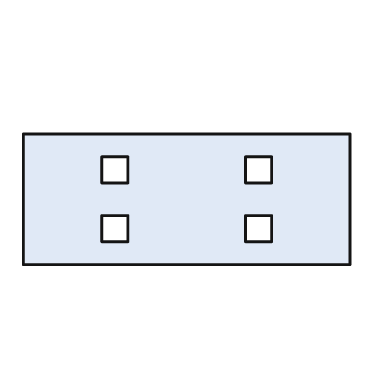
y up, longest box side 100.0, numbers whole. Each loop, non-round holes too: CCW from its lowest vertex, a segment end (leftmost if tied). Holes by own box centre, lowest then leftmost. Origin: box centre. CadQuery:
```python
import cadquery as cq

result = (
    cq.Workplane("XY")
    .moveTo(-50.0, -20.0)
    .lineTo(50.0, -20.0)
    .lineTo(50.0, 20.0)
    .lineTo(-50.0, 20.0)
    .close()
    .moveTo(-26.0, -13.0)
    .lineTo(-18.0, -13.0)
    .lineTo(-18.0, -5.0)
    .lineTo(-26.0, -5.0)
    .close()
    .moveTo(18.0, -13.0)
    .lineTo(26.0, -13.0)
    .lineTo(26.0, -5.0)
    .lineTo(18.0, -5.0)
    .close()
    .moveTo(-26.0, 5.0)
    .lineTo(-18.0, 5.0)
    .lineTo(-18.0, 13.0)
    .lineTo(-26.0, 13.0)
    .close()
    .moveTo(18.0, 5.0)
    .lineTo(26.0, 5.0)
    .lineTo(26.0, 13.0)
    .lineTo(18.0, 13.0)
    .close()
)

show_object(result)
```